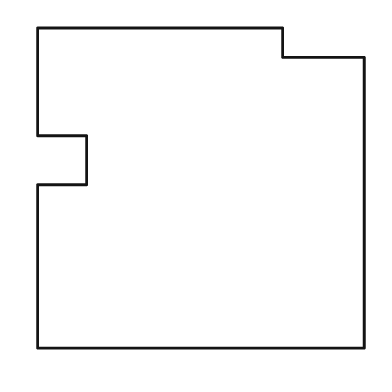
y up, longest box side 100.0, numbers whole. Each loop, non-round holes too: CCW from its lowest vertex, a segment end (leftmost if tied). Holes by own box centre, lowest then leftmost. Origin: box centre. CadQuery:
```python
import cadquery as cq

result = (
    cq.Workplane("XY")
    .moveTo(-50.0, -49.0)
    .lineTo(50.0, -49.0)
    .lineTo(50.0, 40.0)
    .lineTo(25.0, 40.0)
    .lineTo(25.0, 49.0)
    .lineTo(-50.0, 49.0)
    .lineTo(-50.0, 16.0)
    .lineTo(-35.0, 16.0)
    .lineTo(-35.0, 1.0)
    .lineTo(-50.0, 1.0)
    .close()
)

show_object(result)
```